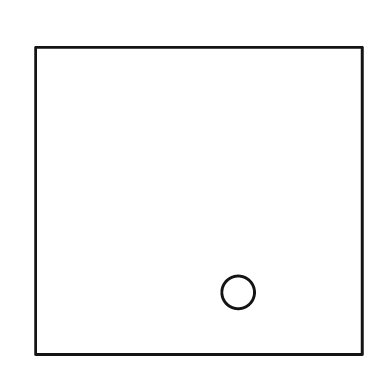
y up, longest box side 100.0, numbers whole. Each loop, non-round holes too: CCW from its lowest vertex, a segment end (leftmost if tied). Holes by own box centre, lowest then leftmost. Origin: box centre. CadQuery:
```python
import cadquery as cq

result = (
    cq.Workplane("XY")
    .moveTo(-50.0, -47.0)
    .lineTo(50.0, -47.0)
    .lineTo(50.0, 47.0)
    .lineTo(-50.0, 47.0)
    .close()
    .moveTo(12.0, -28.0)
    .circle(5.0)
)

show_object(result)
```